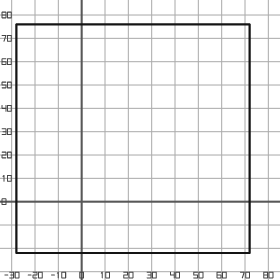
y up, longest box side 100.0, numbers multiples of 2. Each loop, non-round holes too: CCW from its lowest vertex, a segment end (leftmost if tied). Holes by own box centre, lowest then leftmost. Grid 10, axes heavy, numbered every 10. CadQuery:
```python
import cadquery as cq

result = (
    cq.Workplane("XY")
    .moveTo(-28.0, -22.0)
    .lineTo(72.0, -22.0)
    .lineTo(72.0, 76.0)
    .lineTo(-28.0, 76.0)
    .close()
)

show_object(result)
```